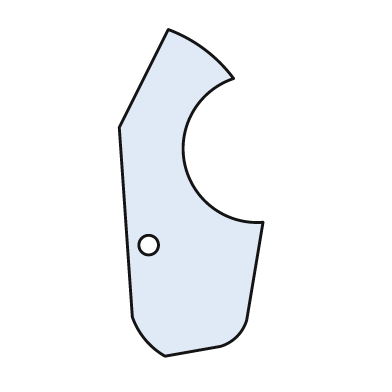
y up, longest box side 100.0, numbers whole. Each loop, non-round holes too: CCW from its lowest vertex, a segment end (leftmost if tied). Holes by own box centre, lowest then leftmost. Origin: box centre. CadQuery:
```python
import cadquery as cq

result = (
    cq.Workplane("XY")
    .moveTo(-8.0, -50.0)
    .lineTo(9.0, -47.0)
    .threePointArc((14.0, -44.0), (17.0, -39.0))
    .lineTo(22.0, -9.0)
    .threePointArc((-2.0, 9.0), (13.0, 35.0))
    .threePointArc((4.0, 44.0), (-7.0, 50.0))
    .lineTo(-22.0, 20.0)
    .lineTo(-18.0, -38.0)
    .threePointArc((-14.0, -45.0), (-8.0, -50.0))
    .close()
    .moveTo(-13.0, -16.0)
    .circle(3.0)
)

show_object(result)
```